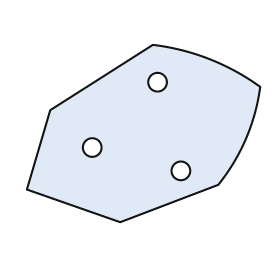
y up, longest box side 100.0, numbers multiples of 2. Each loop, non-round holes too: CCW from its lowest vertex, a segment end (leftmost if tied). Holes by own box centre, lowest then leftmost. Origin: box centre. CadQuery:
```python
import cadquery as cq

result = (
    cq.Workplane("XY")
    .moveTo(-10.0, -38.0)
    .lineTo(32.0, -22.0)
    .threePointArc((44.0, -2.0), (50.0, 20.0))
    .threePointArc((28.0, 32.0), (4.0, 38.0))
    .lineTo(-40.0, 10.0)
    .lineTo(-50.0, -24.0)
    .close()
    .moveTo(16.0, -16.0)
    .circle(4.0)
    .moveTo(-22.0, -6.0)
    .circle(4.0)
    .moveTo(6.0, 22.0)
    .circle(4.0)
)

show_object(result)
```